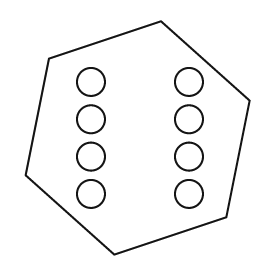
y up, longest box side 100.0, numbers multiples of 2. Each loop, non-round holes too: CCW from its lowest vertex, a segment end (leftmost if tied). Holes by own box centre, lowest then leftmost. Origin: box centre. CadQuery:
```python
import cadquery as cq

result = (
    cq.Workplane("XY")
    .moveTo(-10.0, -50.0)
    .lineTo(38.0, -34.0)
    .lineTo(48.0, 16.0)
    .lineTo(10.0, 50.0)
    .lineTo(-38.0, 34.0)
    .lineTo(-48.0, -16.0)
    .close()
    .moveTo(-20.0, -24.0)
    .circle(6.0)
    .moveTo(22.0, -24.0)
    .circle(6.0)
    .moveTo(-20.0, -8.0)
    .circle(6.0)
    .moveTo(22.0, -8.0)
    .circle(6.0)
    .moveTo(-20.0, 8.0)
    .circle(6.0)
    .moveTo(22.0, 8.0)
    .circle(6.0)
    .moveTo(-20.0, 24.0)
    .circle(6.0)
    .moveTo(22.0, 24.0)
    .circle(6.0)
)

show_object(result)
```